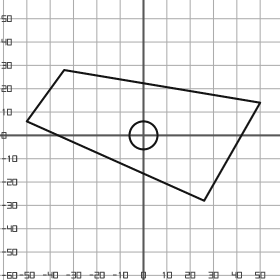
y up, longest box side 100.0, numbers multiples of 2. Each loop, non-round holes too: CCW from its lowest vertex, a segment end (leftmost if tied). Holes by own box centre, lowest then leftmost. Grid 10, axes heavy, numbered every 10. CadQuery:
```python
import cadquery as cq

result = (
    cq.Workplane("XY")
    .moveTo(26.0, -28.0)
    .lineTo(50.0, 14.0)
    .lineTo(-34.0, 28.0)
    .lineTo(-50.0, 6.0)
    .close()
    .moveTo(0.0, 0.0)
    .circle(6.0)
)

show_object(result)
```